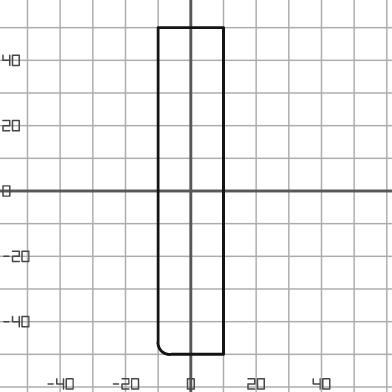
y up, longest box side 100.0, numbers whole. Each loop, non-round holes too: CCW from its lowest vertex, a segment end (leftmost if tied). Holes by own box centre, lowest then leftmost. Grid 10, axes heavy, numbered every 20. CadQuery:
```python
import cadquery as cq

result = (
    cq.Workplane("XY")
    .moveTo(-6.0, -50.0)
    .lineTo(10.0, -50.0)
    .lineTo(10.0, 50.0)
    .lineTo(-10.0, 50.0)
    .lineTo(-10.0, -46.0)
    .threePointArc((-9.0, -49.0), (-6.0, -50.0))
    .close()
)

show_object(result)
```